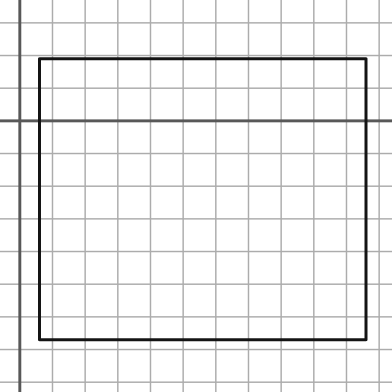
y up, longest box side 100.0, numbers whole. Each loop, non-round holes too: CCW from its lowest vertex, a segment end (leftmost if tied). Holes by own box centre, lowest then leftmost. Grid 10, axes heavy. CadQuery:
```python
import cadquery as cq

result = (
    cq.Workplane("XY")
    .moveTo(6.0, -67.0)
    .lineTo(106.0, -67.0)
    .lineTo(106.0, 19.0)
    .lineTo(6.0, 19.0)
    .close()
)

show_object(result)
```